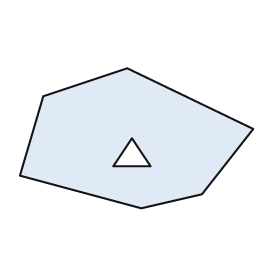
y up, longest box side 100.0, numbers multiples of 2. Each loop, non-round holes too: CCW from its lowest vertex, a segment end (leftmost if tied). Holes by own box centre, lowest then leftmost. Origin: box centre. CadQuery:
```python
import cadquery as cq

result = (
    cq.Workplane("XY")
    .moveTo(2.0, -30.0)
    .lineTo(28.0, -24.0)
    .lineTo(50.0, 4.0)
    .lineTo(-4.0, 30.0)
    .lineTo(-40.0, 18.0)
    .lineTo(-50.0, -16.0)
    .close()
    .moveTo(-10.0, -12.0)
    .lineTo(6.0, -12.0)
    .lineTo(-2.0, 0.0)
    .close()
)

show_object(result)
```